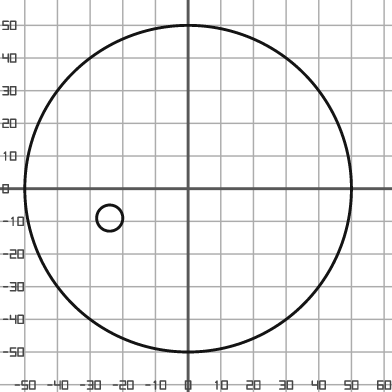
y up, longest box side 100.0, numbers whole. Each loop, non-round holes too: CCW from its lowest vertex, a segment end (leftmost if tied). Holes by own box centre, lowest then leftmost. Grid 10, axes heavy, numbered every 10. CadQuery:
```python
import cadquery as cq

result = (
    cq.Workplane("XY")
    .moveTo(0.0, 0.0)
    .circle(50.0)
    .moveTo(-24.0, -9.0)
    .circle(4.0)
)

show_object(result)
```